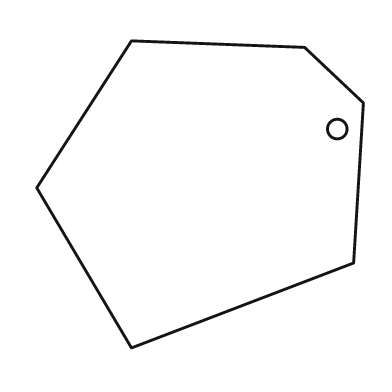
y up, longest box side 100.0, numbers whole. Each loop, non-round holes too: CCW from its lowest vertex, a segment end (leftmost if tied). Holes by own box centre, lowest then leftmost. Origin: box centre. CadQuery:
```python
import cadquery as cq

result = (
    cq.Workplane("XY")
    .moveTo(-21.0, -47.0)
    .lineTo(47.0, -21.0)
    .lineTo(50.0, 28.0)
    .lineTo(32.0, 45.0)
    .lineTo(-21.0, 47.0)
    .lineTo(-50.0, 2.0)
    .close()
    .moveTo(42.0, 20.0)
    .circle(3.0)
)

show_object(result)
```